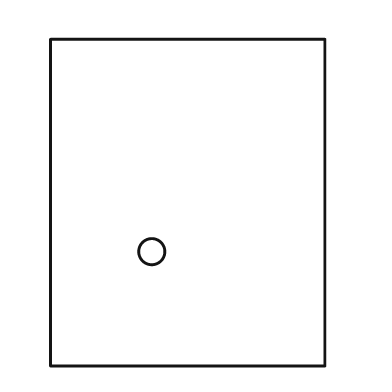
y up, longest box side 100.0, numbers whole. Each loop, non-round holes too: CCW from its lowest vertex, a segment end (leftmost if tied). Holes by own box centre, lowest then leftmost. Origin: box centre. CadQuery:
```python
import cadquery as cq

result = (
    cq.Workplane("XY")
    .moveTo(-42.0, -50.0)
    .lineTo(42.0, -50.0)
    .lineTo(42.0, 50.0)
    .lineTo(-42.0, 50.0)
    .close()
    .moveTo(-11.0, -15.0)
    .circle(4.0)
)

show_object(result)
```